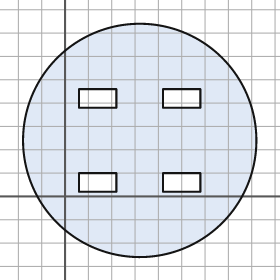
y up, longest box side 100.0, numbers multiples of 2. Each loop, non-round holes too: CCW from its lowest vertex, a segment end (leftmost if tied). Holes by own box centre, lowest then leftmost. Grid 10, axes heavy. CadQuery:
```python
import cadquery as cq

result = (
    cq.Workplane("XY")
    .moveTo(32.0, 24.0)
    .circle(50.0)
    .moveTo(6.0, 2.0)
    .lineTo(22.0, 2.0)
    .lineTo(22.0, 10.0)
    .lineTo(6.0, 10.0)
    .close()
    .moveTo(42.0, 2.0)
    .lineTo(58.0, 2.0)
    .lineTo(58.0, 10.0)
    .lineTo(42.0, 10.0)
    .close()
    .moveTo(6.0, 38.0)
    .lineTo(22.0, 38.0)
    .lineTo(22.0, 46.0)
    .lineTo(6.0, 46.0)
    .close()
    .moveTo(42.0, 38.0)
    .lineTo(58.0, 38.0)
    .lineTo(58.0, 46.0)
    .lineTo(42.0, 46.0)
    .close()
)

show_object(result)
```